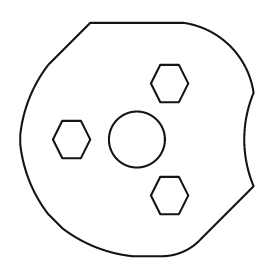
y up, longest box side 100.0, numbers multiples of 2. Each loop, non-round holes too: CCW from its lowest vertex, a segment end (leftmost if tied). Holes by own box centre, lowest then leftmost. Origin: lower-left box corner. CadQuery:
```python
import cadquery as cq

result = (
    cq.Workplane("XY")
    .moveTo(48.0, 0.0)
    .lineTo(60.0, 0.0)
    .threePointArc((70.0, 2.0), (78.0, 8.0))
    .lineTo(100.0, 30.0)
    .threePointArc((96.0, 50.0), (100.0, 70.0))
    .threePointArc((90.0, 90.0), (70.0, 100.0))
    .lineTo(30.0, 100.0)
    .lineTo(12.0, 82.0)
    .threePointArc((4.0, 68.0), (0.0, 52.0))
    .lineTo(0.0, 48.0)
    .threePointArc((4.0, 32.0), (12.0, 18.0))
    .lineTo(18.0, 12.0)
    .threePointArc((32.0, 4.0), (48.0, 0.0))
    .close()
    .moveTo(60.0, 18.0)
    .lineTo(68.0, 18.0)
    .lineTo(72.0, 26.0)
    .lineTo(68.0, 34.0)
    .lineTo(60.0, 34.0)
    .lineTo(56.0, 26.0)
    .close()
    .moveTo(18.0, 42.0)
    .lineTo(26.0, 42.0)
    .lineTo(30.0, 50.0)
    .lineTo(26.0, 58.0)
    .lineTo(18.0, 58.0)
    .lineTo(14.0, 50.0)
    .close()
    .moveTo(50.0, 50.0)
    .circle(12.0)
    .moveTo(60.0, 66.0)
    .lineTo(68.0, 66.0)
    .lineTo(72.0, 74.0)
    .lineTo(68.0, 82.0)
    .lineTo(60.0, 82.0)
    .lineTo(56.0, 74.0)
    .close()
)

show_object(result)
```